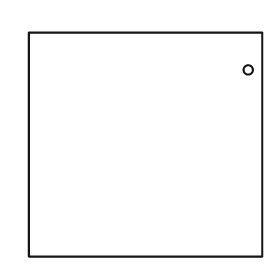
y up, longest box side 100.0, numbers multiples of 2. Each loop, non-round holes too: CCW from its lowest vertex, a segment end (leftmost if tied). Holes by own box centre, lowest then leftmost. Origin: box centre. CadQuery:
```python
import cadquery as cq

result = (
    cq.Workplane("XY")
    .moveTo(-50.0, -48.0)
    .lineTo(50.0, -48.0)
    .lineTo(50.0, 48.0)
    .lineTo(-50.0, 48.0)
    .close()
    .moveTo(44.0, 32.0)
    .circle(2.0)
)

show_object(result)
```